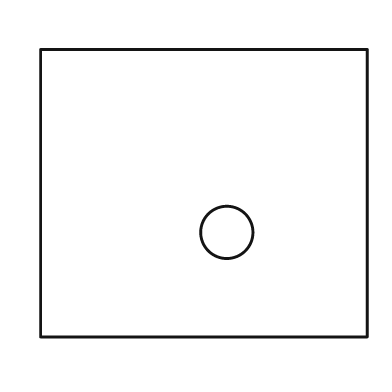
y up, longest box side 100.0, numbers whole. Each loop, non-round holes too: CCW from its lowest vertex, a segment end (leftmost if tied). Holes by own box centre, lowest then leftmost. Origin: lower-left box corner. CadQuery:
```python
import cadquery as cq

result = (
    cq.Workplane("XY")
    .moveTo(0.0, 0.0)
    .lineTo(100.0, 0.0)
    .lineTo(100.0, 88.0)
    .lineTo(0.0, 88.0)
    .close()
    .moveTo(57.0, 32.0)
    .circle(8.0)
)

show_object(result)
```